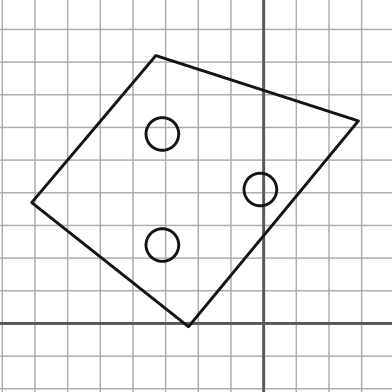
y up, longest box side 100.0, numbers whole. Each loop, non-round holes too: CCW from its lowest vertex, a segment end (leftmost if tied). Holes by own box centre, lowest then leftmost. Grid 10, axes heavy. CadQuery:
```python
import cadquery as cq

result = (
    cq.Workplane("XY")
    .moveTo(-23.0, -1.0)
    .lineTo(29.0, 62.0)
    .lineTo(-33.0, 82.0)
    .lineTo(-71.0, 37.0)
    .close()
    .moveTo(-31.0, 24.0)
    .circle(5.0)
    .moveTo(-1.0, 41.0)
    .circle(5.0)
    .moveTo(-31.0, 58.0)
    .circle(5.0)
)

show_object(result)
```